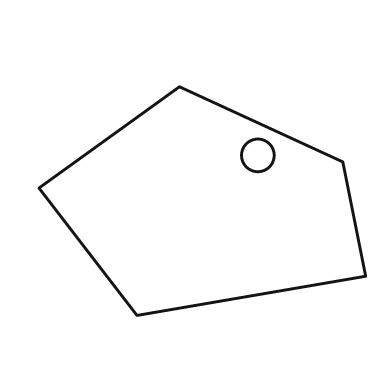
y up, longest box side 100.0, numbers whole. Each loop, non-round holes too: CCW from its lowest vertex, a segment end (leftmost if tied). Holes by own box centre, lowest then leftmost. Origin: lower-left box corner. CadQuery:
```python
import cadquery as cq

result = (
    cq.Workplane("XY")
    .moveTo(30.0, 0.0)
    .lineTo(100.0, 12.0)
    .lineTo(93.0, 47.0)
    .lineTo(43.0, 70.0)
    .lineTo(0.0, 39.0)
    .close()
    .moveTo(67.0, 49.0)
    .circle(5.0)
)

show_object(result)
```